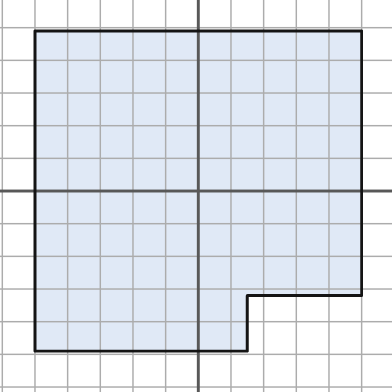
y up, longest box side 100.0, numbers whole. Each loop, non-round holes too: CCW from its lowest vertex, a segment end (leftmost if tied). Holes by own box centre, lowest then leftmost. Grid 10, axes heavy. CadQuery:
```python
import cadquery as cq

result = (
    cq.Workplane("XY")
    .moveTo(-50.0, -49.0)
    .lineTo(15.0, -49.0)
    .lineTo(15.0, -32.0)
    .lineTo(50.0, -32.0)
    .lineTo(50.0, 49.0)
    .lineTo(-50.0, 49.0)
    .close()
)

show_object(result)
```